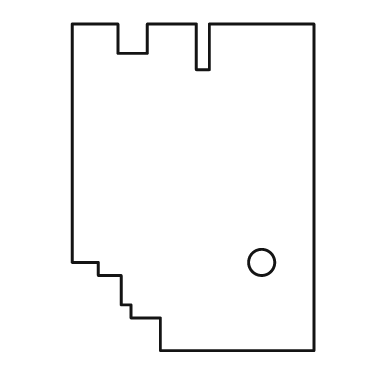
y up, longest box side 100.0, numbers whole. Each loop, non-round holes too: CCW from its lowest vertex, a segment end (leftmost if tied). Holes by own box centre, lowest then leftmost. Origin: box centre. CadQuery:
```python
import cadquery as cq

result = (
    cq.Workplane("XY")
    .moveTo(-10.0, -50.0)
    .lineTo(37.0, -50.0)
    .lineTo(37.0, 50.0)
    .lineTo(5.0, 50.0)
    .lineTo(5.0, 36.0)
    .lineTo(1.0, 36.0)
    .lineTo(1.0, 50.0)
    .lineTo(-14.0, 50.0)
    .lineTo(-14.0, 41.0)
    .lineTo(-23.0, 41.0)
    .lineTo(-23.0, 50.0)
    .lineTo(-37.0, 50.0)
    .lineTo(-37.0, -23.0)
    .lineTo(-29.0, -23.0)
    .lineTo(-29.0, -27.0)
    .lineTo(-22.0, -27.0)
    .lineTo(-22.0, -36.0)
    .lineTo(-19.0, -36.0)
    .lineTo(-19.0, -40.0)
    .lineTo(-10.0, -40.0)
    .close()
    .moveTo(21.0, -23.0)
    .circle(4.0)
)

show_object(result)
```